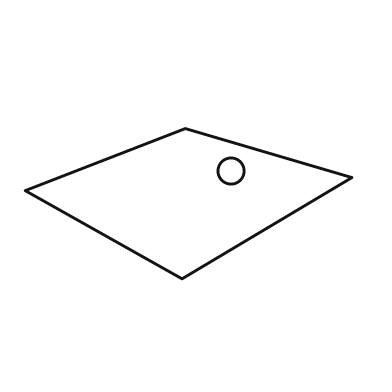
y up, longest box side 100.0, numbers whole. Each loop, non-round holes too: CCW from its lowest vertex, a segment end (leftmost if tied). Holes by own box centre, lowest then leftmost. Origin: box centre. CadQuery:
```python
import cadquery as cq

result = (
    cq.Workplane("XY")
    .moveTo(-2.0, -23.0)
    .lineTo(50.0, 8.0)
    .lineTo(-1.0, 23.0)
    .lineTo(-50.0, 4.0)
    .close()
    .moveTo(13.0, 10.0)
    .circle(4.0)
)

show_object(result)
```